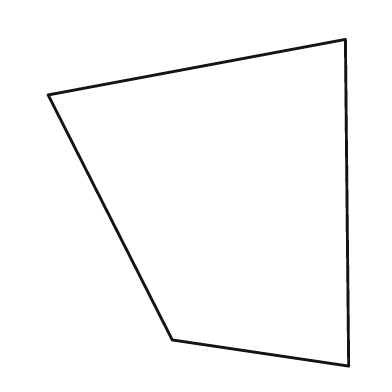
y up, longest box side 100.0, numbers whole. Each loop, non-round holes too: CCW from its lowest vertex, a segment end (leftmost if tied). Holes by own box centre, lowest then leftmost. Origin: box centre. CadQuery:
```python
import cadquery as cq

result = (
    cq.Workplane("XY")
    .moveTo(46.0, -50.0)
    .lineTo(45.0, 50.0)
    .lineTo(-46.0, 33.0)
    .lineTo(-8.0, -42.0)
    .close()
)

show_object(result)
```